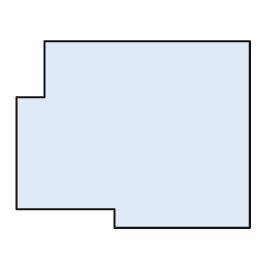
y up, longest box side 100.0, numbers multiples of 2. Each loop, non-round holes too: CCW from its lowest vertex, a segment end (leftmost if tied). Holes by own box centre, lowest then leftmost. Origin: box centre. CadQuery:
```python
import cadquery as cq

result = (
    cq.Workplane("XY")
    .moveTo(-8.0, -40.0)
    .lineTo(50.0, -40.0)
    .lineTo(50.0, 40.0)
    .lineTo(-38.0, 40.0)
    .lineTo(-38.0, 16.0)
    .lineTo(-50.0, 16.0)
    .lineTo(-50.0, -32.0)
    .lineTo(-8.0, -32.0)
    .close()
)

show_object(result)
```